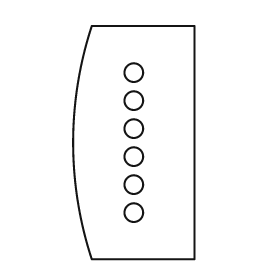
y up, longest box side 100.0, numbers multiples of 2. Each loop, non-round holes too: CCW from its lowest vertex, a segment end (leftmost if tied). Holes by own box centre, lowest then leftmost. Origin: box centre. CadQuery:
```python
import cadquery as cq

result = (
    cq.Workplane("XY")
    .moveTo(-18.0, -50.0)
    .lineTo(26.0, -50.0)
    .lineTo(26.0, 50.0)
    .lineTo(-18.0, 50.0)
    .threePointArc((-26.0, 0.0), (-18.0, -50.0))
    .close()
    .moveTo(0.0, -30.0)
    .circle(4.0)
    .moveTo(0.0, -18.0)
    .circle(4.0)
    .moveTo(0.0, -6.0)
    .circle(4.0)
    .moveTo(0.0, 6.0)
    .circle(4.0)
    .moveTo(0.0, 18.0)
    .circle(4.0)
    .moveTo(0.0, 30.0)
    .circle(4.0)
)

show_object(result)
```